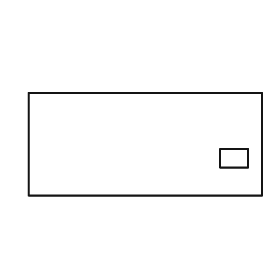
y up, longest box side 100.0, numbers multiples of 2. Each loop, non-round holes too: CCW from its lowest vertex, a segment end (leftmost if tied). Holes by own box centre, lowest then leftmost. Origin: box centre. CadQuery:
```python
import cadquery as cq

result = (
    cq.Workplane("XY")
    .moveTo(-50.0, -22.0)
    .lineTo(50.0, -22.0)
    .lineTo(50.0, 22.0)
    .lineTo(-50.0, 22.0)
    .close()
    .moveTo(32.0, -10.0)
    .lineTo(44.0, -10.0)
    .lineTo(44.0, -2.0)
    .lineTo(32.0, -2.0)
    .close()
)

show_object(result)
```